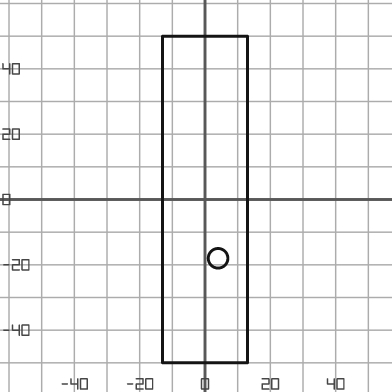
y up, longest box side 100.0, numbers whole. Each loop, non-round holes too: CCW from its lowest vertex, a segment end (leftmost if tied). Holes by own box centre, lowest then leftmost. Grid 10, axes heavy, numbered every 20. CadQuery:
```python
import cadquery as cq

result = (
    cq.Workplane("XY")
    .moveTo(-13.0, -50.0)
    .lineTo(13.0, -50.0)
    .lineTo(13.0, 50.0)
    .lineTo(-13.0, 50.0)
    .close()
    .moveTo(4.0, -18.0)
    .circle(3.0)
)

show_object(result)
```